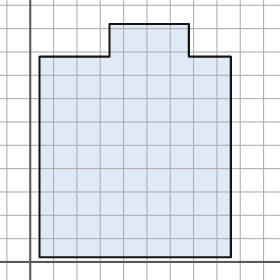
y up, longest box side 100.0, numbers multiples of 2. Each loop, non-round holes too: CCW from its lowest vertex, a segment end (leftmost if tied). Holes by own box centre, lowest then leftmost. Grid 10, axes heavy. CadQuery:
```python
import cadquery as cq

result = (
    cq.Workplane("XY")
    .moveTo(4.0, 2.0)
    .lineTo(86.0, 2.0)
    .lineTo(86.0, 88.0)
    .lineTo(68.0, 88.0)
    .lineTo(68.0, 102.0)
    .lineTo(34.0, 102.0)
    .lineTo(34.0, 88.0)
    .lineTo(4.0, 88.0)
    .close()
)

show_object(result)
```